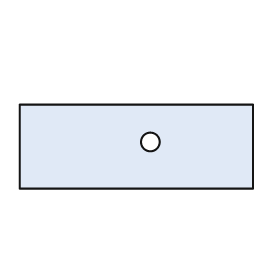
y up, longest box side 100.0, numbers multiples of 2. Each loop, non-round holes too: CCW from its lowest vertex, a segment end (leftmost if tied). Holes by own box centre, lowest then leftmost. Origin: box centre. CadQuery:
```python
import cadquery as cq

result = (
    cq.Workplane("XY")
    .moveTo(-50.0, -18.0)
    .lineTo(50.0, -18.0)
    .lineTo(50.0, 18.0)
    .lineTo(-50.0, 18.0)
    .close()
    .moveTo(6.0, 2.0)
    .circle(4.0)
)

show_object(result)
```